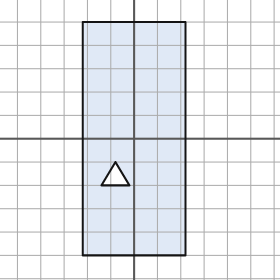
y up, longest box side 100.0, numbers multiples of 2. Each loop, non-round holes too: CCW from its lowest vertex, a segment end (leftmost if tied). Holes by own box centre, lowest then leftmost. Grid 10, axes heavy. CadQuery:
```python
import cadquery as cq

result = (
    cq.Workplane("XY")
    .moveTo(-22.0, -50.0)
    .lineTo(22.0, -50.0)
    .lineTo(22.0, 50.0)
    .lineTo(-22.0, 50.0)
    .close()
    .moveTo(-14.0, -20.0)
    .lineTo(-2.0, -20.0)
    .lineTo(-8.0, -10.0)
    .close()
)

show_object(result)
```